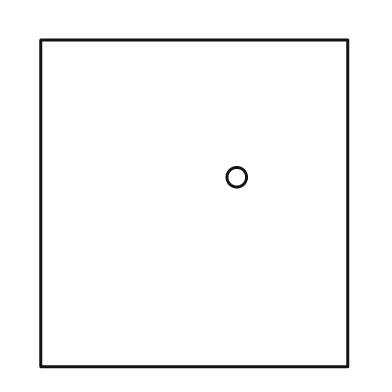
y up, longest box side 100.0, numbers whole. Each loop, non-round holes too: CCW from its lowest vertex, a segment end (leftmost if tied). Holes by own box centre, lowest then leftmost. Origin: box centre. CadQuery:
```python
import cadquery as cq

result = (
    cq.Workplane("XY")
    .moveTo(-47.0, -50.0)
    .lineTo(47.0, -50.0)
    .lineTo(47.0, 50.0)
    .lineTo(-47.0, 50.0)
    .close()
    .moveTo(13.0, 8.0)
    .circle(3.0)
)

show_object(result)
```